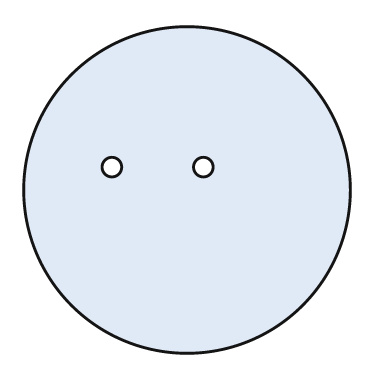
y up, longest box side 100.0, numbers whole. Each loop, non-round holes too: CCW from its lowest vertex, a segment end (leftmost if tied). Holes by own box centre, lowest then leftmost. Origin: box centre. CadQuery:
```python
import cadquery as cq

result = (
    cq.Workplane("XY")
    .moveTo(0.0, 0.0)
    .circle(50.0)
    .moveTo(-23.0, 7.0)
    .circle(3.0)
    .moveTo(5.0, 7.0)
    .circle(3.0)
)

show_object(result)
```